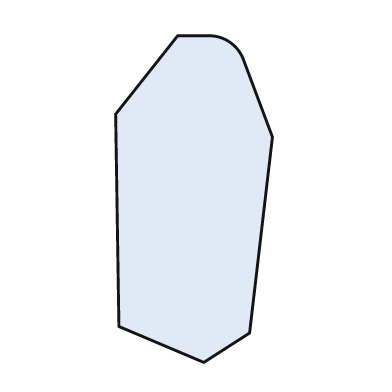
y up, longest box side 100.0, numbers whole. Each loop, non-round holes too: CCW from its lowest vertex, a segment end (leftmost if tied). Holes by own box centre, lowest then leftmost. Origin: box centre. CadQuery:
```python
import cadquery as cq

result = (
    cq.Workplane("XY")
    .moveTo(3.0, -50.0)
    .lineTo(17.0, -41.0)
    .lineTo(24.0, 19.0)
    .lineTo(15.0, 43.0)
    .threePointArc((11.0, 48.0), (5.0, 50.0))
    .lineTo(-5.0, 50.0)
    .lineTo(-24.0, 26.0)
    .lineTo(-23.0, -39.0)
    .close()
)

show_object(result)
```